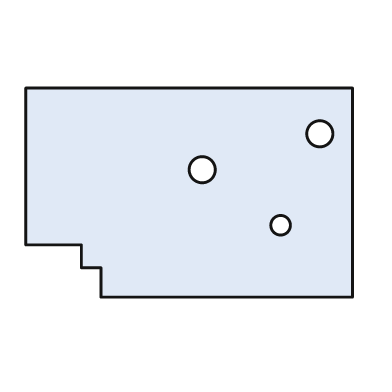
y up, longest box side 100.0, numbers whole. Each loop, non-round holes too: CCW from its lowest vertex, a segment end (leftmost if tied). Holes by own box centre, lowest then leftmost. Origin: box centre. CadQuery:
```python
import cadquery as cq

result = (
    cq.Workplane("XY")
    .moveTo(-27.0, -32.0)
    .lineTo(50.0, -32.0)
    .lineTo(50.0, 32.0)
    .lineTo(-50.0, 32.0)
    .lineTo(-50.0, -16.0)
    .lineTo(-33.0, -16.0)
    .lineTo(-33.0, -23.0)
    .lineTo(-27.0, -23.0)
    .close()
    .moveTo(28.0, -10.0)
    .circle(3.0)
    .moveTo(4.0, 7.0)
    .circle(4.0)
    .moveTo(40.0, 18.0)
    .circle(4.0)
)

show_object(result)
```